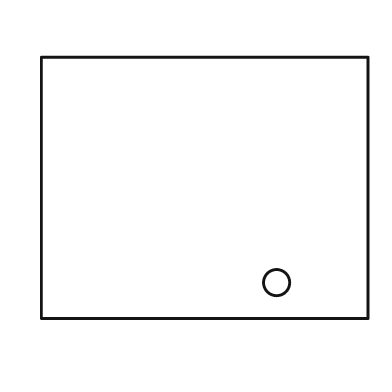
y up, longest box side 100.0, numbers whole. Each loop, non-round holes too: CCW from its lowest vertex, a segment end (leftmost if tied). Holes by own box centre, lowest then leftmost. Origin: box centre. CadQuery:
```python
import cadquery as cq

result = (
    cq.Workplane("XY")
    .moveTo(-50.0, -40.0)
    .lineTo(50.0, -40.0)
    .lineTo(50.0, 40.0)
    .lineTo(-50.0, 40.0)
    .close()
    .moveTo(22.0, -29.0)
    .circle(4.0)
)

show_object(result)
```